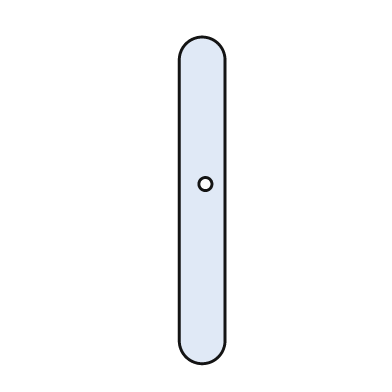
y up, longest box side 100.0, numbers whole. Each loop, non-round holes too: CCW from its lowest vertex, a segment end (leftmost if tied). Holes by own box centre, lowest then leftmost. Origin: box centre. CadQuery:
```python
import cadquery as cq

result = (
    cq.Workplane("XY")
    .moveTo(-7.0, -43.0)
    .threePointArc((0.0, -50.0), (7.0, -43.0))
    .lineTo(7.0, 43.0)
    .threePointArc((0.0, 50.0), (-7.0, 43.0))
    .close()
    .moveTo(1.0, 5.0)
    .circle(2.0)
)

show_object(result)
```